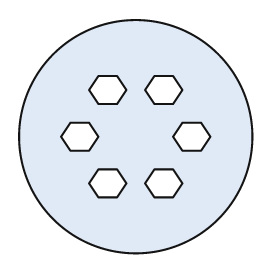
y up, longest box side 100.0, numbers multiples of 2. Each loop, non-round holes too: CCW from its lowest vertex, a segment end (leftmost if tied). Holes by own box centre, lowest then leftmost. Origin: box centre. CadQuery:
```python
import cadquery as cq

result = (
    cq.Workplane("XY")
    .moveTo(0.0, 0.0)
    .circle(50.0)
    .moveTo(-16.0, -26.0)
    .lineTo(-8.0, -26.0)
    .lineTo(-4.0, -20.0)
    .lineTo(-8.0, -14.0)
    .lineTo(-16.0, -14.0)
    .lineTo(-20.0, -20.0)
    .close()
    .moveTo(8.0, -26.0)
    .lineTo(16.0, -26.0)
    .lineTo(20.0, -20.0)
    .lineTo(16.0, -14.0)
    .lineTo(8.0, -14.0)
    .lineTo(4.0, -20.0)
    .close()
    .moveTo(-28.0, -6.0)
    .lineTo(-20.0, -6.0)
    .lineTo(-16.0, 0.0)
    .lineTo(-20.0, 6.0)
    .lineTo(-28.0, 6.0)
    .lineTo(-32.0, 0.0)
    .close()
    .moveTo(20.0, -6.0)
    .lineTo(28.0, -6.0)
    .lineTo(32.0, 0.0)
    .lineTo(28.0, 6.0)
    .lineTo(20.0, 6.0)
    .lineTo(16.0, 0.0)
    .close()
    .moveTo(-16.0, 14.0)
    .lineTo(-8.0, 14.0)
    .lineTo(-4.0, 20.0)
    .lineTo(-8.0, 26.0)
    .lineTo(-16.0, 26.0)
    .lineTo(-20.0, 20.0)
    .close()
    .moveTo(8.0, 14.0)
    .lineTo(16.0, 14.0)
    .lineTo(20.0, 20.0)
    .lineTo(16.0, 26.0)
    .lineTo(8.0, 26.0)
    .lineTo(4.0, 20.0)
    .close()
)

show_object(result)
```